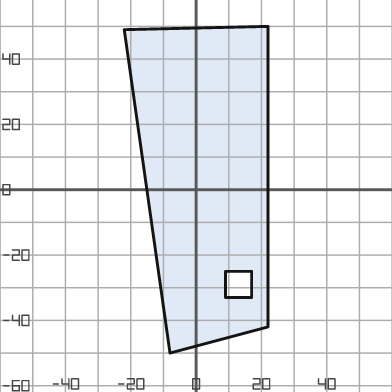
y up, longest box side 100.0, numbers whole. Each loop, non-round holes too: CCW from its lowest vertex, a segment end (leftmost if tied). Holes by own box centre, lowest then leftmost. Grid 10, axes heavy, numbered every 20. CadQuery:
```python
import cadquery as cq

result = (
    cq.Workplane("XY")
    .moveTo(-8.0, -50.0)
    .lineTo(22.0, -42.0)
    .lineTo(22.0, 50.0)
    .lineTo(-22.0, 49.0)
    .close()
    .moveTo(9.0, -33.0)
    .lineTo(17.0, -33.0)
    .lineTo(17.0, -25.0)
    .lineTo(9.0, -25.0)
    .close()
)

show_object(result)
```